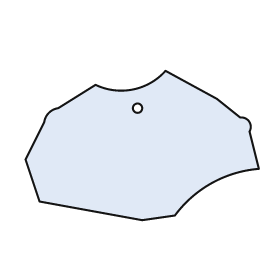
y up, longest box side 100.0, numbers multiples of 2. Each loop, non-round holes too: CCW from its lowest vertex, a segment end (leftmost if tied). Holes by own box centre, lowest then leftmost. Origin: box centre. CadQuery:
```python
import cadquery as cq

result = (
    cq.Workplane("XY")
    .moveTo(0.0, -32.0)
    .lineTo(14.0, -30.0)
    .threePointArc((30.0, -16.0), (50.0, -10.0))
    .lineTo(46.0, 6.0)
    .threePointArc((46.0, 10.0), (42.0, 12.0))
    .lineTo(32.0, 20.0)
    .lineTo(10.0, 32.0)
    .threePointArc((-4.0, 24.0), (-20.0, 26.0))
    .lineTo(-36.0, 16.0)
    .threePointArc((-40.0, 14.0), (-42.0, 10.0))
    .lineTo(-50.0, -6.0)
    .lineTo(-44.0, -24.0)
    .close()
    .moveTo(-2.0, 16.0)
    .circle(2.0)
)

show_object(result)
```